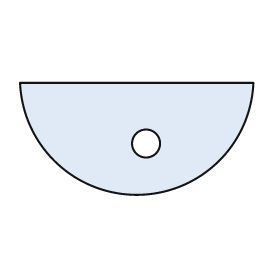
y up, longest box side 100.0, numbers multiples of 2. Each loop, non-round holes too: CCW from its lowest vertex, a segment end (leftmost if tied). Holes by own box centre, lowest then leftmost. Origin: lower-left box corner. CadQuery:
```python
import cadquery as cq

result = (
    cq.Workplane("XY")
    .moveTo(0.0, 48.0)
    .threePointArc((50.0, 0.0), (100.0, 48.0))
    .close()
    .moveTo(54.0, 22.0)
    .circle(6.0)
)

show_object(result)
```